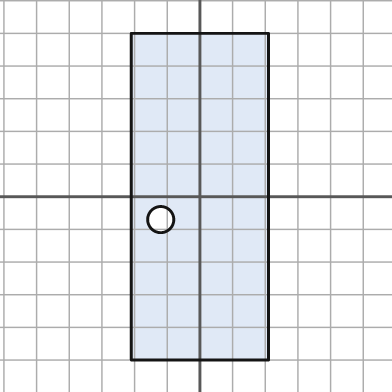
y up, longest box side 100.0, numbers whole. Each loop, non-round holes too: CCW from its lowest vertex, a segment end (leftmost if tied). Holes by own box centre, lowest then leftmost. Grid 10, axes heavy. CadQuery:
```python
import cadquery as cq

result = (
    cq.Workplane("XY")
    .moveTo(-21.0, -50.0)
    .lineTo(21.0, -50.0)
    .lineTo(21.0, 50.0)
    .lineTo(-21.0, 50.0)
    .close()
    .moveTo(-12.0, -7.0)
    .circle(4.0)
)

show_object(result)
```